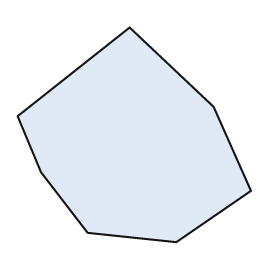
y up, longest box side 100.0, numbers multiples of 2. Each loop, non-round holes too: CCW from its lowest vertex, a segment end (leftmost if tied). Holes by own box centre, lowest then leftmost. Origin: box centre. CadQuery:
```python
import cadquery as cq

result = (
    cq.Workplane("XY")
    .moveTo(18.0, -46.0)
    .lineTo(50.0, -24.0)
    .lineTo(34.0, 12.0)
    .lineTo(-2.0, 46.0)
    .lineTo(-50.0, 8.0)
    .lineTo(-40.0, -16.0)
    .lineTo(-20.0, -42.0)
    .close()
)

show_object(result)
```